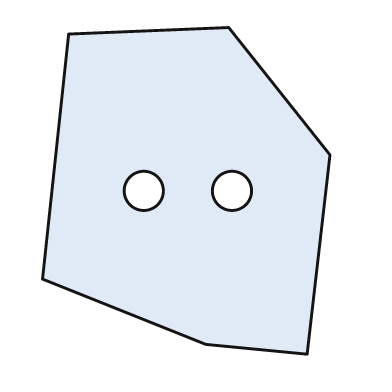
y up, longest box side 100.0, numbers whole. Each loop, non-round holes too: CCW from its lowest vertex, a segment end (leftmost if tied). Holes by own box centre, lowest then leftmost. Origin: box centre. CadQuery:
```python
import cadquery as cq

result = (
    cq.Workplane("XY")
    .moveTo(37.0, -50.0)
    .lineTo(44.0, 11.0)
    .lineTo(13.0, 50.0)
    .lineTo(-36.0, 48.0)
    .lineTo(-44.0, -27.0)
    .lineTo(6.0, -47.0)
    .close()
    .moveTo(-13.0, 0.0)
    .circle(6.0)
    .moveTo(14.0, 0.0)
    .circle(6.0)
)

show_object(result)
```